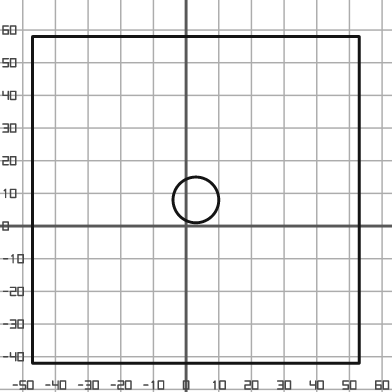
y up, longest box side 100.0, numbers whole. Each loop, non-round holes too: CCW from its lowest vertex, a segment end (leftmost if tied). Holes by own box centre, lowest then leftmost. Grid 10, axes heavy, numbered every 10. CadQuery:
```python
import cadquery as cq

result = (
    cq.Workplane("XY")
    .moveTo(-47.0, -42.0)
    .lineTo(53.0, -42.0)
    .lineTo(53.0, 58.0)
    .lineTo(-47.0, 58.0)
    .close()
    .moveTo(3.0, 8.0)
    .circle(7.0)
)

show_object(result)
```